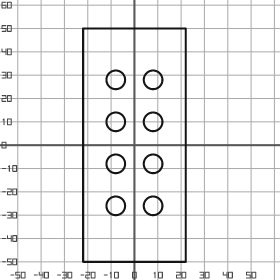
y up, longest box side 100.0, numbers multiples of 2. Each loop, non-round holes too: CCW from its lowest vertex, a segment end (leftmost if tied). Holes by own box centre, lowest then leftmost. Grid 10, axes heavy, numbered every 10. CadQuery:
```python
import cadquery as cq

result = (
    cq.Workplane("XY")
    .moveTo(-22.0, -50.0)
    .lineTo(22.0, -50.0)
    .lineTo(22.0, 50.0)
    .lineTo(-22.0, 50.0)
    .close()
    .moveTo(-8.0, -26.0)
    .circle(4.0)
    .moveTo(8.0, -26.0)
    .circle(4.0)
    .moveTo(-8.0, -8.0)
    .circle(4.0)
    .moveTo(8.0, -8.0)
    .circle(4.0)
    .moveTo(-8.0, 10.0)
    .circle(4.0)
    .moveTo(8.0, 10.0)
    .circle(4.0)
    .moveTo(-8.0, 28.0)
    .circle(4.0)
    .moveTo(8.0, 28.0)
    .circle(4.0)
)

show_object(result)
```